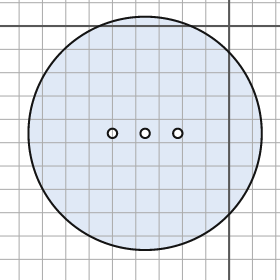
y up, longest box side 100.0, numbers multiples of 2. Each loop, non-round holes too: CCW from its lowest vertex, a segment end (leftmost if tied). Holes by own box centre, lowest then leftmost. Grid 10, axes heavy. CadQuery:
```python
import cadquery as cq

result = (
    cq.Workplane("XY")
    .moveTo(-36.0, -46.0)
    .circle(50.0)
    .moveTo(-50.0, -46.0)
    .circle(2.0)
    .moveTo(-36.0, -46.0)
    .circle(2.0)
    .moveTo(-22.0, -46.0)
    .circle(2.0)
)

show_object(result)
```